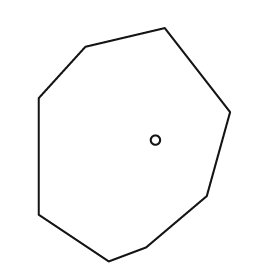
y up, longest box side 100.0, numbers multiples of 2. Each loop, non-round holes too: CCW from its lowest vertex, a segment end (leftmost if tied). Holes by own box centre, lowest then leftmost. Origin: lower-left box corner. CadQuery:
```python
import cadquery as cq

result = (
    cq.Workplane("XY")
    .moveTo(30.0, 0.0)
    .lineTo(46.0, 6.0)
    .lineTo(72.0, 28.0)
    .lineTo(82.0, 64.0)
    .lineTo(54.0, 100.0)
    .lineTo(20.0, 92.0)
    .lineTo(0.0, 70.0)
    .lineTo(0.0, 20.0)
    .close()
    .moveTo(50.0, 52.0)
    .circle(2.0)
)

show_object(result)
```